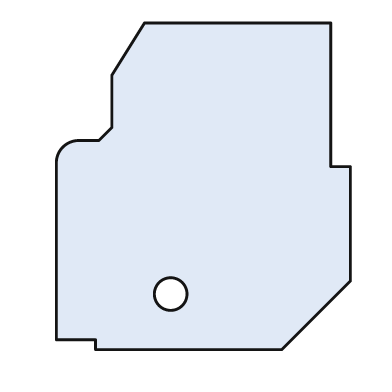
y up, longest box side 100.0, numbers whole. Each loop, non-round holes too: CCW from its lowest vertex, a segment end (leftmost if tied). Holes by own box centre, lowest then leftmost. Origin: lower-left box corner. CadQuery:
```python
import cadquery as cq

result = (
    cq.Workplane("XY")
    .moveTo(12.0, 0.0)
    .lineTo(69.0, 0.0)
    .lineTo(90.0, 21.0)
    .lineTo(90.0, 56.0)
    .lineTo(84.0, 56.0)
    .lineTo(84.0, 100.0)
    .lineTo(27.0, 100.0)
    .lineTo(17.0, 84.0)
    .lineTo(17.0, 68.0)
    .lineTo(13.0, 64.0)
    .lineTo(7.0, 64.0)
    .threePointArc((2.0, 62.0), (0.0, 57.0))
    .lineTo(0.0, 3.0)
    .lineTo(12.0, 3.0)
    .close()
    .moveTo(35.0, 17.0)
    .circle(5.0)
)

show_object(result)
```